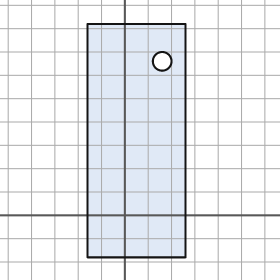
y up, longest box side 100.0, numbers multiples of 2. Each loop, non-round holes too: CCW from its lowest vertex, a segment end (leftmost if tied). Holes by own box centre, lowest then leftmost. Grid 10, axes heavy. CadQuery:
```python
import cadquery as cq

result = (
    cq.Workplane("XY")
    .moveTo(-16.0, -18.0)
    .lineTo(26.0, -18.0)
    .lineTo(26.0, 82.0)
    .lineTo(-16.0, 82.0)
    .close()
    .moveTo(16.0, 66.0)
    .circle(4.0)
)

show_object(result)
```